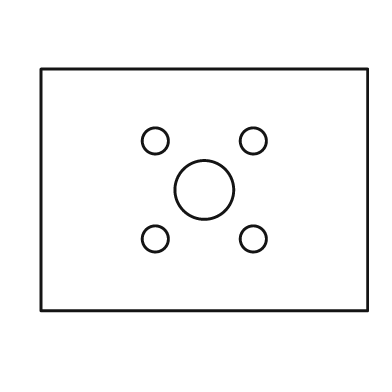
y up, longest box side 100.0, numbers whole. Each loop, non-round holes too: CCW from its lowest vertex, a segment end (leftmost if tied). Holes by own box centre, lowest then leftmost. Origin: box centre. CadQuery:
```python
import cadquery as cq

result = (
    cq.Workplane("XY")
    .moveTo(-50.0, -37.0)
    .lineTo(50.0, -37.0)
    .lineTo(50.0, 37.0)
    .lineTo(-50.0, 37.0)
    .close()
    .moveTo(-15.0, -15.0)
    .circle(4.0)
    .moveTo(15.0, -15.0)
    .circle(4.0)
    .moveTo(0.0, 0.0)
    .circle(9.0)
    .moveTo(-15.0, 15.0)
    .circle(4.0)
    .moveTo(15.0, 15.0)
    .circle(4.0)
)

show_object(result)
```